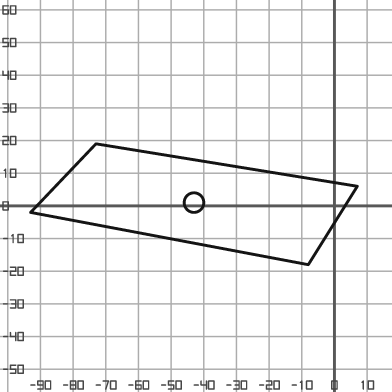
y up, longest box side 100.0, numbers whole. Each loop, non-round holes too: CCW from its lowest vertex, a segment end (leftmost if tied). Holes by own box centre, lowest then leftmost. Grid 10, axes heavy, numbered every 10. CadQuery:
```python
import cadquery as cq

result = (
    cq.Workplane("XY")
    .moveTo(-8.0, -18.0)
    .lineTo(7.0, 6.0)
    .lineTo(-73.0, 19.0)
    .lineTo(-93.0, -2.0)
    .close()
    .moveTo(-43.0, 1.0)
    .circle(3.0)
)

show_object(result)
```